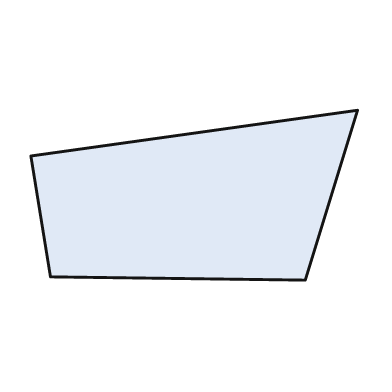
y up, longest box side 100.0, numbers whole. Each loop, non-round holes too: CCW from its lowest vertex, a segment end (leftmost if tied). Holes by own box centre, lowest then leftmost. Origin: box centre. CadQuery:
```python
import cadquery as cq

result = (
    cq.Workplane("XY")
    .moveTo(34.0, -26.0)
    .lineTo(50.0, 26.0)
    .lineTo(-50.0, 12.0)
    .lineTo(-44.0, -25.0)
    .close()
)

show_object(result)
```